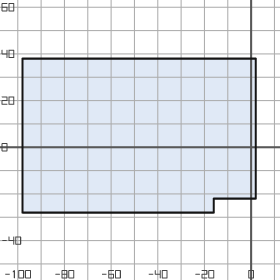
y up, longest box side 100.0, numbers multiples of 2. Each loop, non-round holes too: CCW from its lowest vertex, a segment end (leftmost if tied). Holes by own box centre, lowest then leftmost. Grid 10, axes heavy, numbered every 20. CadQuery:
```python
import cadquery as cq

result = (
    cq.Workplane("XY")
    .moveTo(-98.0, -28.0)
    .lineTo(-16.0, -28.0)
    .lineTo(-16.0, -22.0)
    .lineTo(2.0, -22.0)
    .lineTo(2.0, 38.0)
    .lineTo(-98.0, 38.0)
    .close()
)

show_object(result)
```